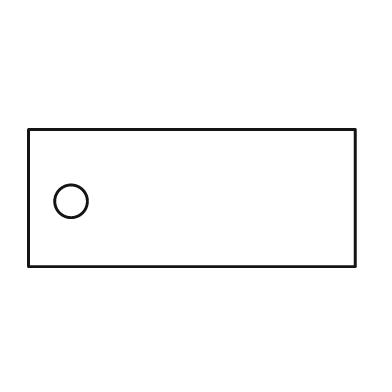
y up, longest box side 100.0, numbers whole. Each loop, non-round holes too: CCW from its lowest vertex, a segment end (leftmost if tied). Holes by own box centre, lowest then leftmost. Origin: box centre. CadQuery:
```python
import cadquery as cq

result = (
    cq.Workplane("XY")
    .moveTo(-50.0, -21.0)
    .lineTo(50.0, -21.0)
    .lineTo(50.0, 21.0)
    .lineTo(-50.0, 21.0)
    .close()
    .moveTo(-37.0, -1.0)
    .circle(5.0)
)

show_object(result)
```